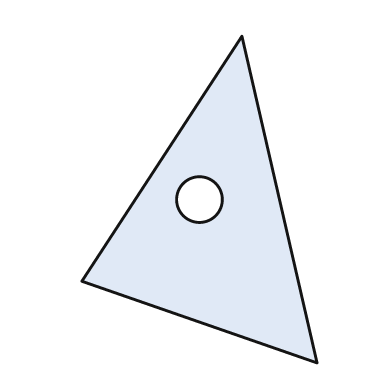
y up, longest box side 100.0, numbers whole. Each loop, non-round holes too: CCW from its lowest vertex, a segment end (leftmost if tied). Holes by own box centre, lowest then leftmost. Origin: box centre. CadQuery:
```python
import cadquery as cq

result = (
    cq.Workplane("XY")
    .moveTo(36.0, -50.0)
    .lineTo(13.0, 50.0)
    .lineTo(-36.0, -25.0)
    .close()
    .moveTo(0.0, 0.0)
    .circle(7.0)
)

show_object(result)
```